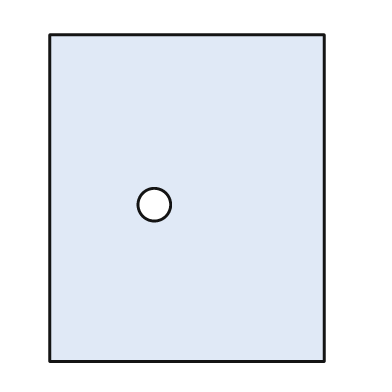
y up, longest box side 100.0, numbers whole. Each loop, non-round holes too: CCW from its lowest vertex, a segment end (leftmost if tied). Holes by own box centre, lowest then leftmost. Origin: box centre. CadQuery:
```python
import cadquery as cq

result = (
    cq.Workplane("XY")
    .moveTo(-42.0, -50.0)
    .lineTo(42.0, -50.0)
    .lineTo(42.0, 50.0)
    .lineTo(-42.0, 50.0)
    .close()
    .moveTo(-10.0, -2.0)
    .circle(5.0)
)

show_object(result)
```